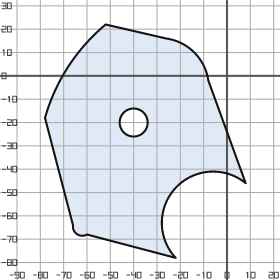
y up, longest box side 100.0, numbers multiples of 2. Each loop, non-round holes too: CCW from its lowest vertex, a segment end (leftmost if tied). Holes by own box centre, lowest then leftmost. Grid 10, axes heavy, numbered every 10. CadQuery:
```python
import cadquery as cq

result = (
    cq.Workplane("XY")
    .moveTo(-22.0, -78.0)
    .threePointArc((-22.0, -48.0), (8.0, -46.0))
    .lineTo(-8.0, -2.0)
    .threePointArc((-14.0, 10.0), (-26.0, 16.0))
    .lineTo(-52.0, 22.0)
    .threePointArc((-68.0, 4.0), (-78.0, -18.0))
    .lineTo(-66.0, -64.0)
    .threePointArc((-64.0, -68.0), (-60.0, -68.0))
    .close()
    .moveTo(-40.0, -20.0)
    .circle(6.0)
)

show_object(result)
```